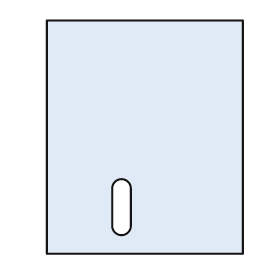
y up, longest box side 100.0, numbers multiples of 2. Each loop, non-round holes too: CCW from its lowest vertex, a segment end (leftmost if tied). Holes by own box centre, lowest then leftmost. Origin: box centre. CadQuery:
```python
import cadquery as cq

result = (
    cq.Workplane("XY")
    .moveTo(-42.0, -50.0)
    .lineTo(42.0, -50.0)
    .lineTo(42.0, 50.0)
    .lineTo(-42.0, 50.0)
    .close()
    .moveTo(-14.0, -38.0)
    .threePointArc((-10.0, -42.0), (-6.0, -38.0))
    .lineTo(-6.0, -22.0)
    .threePointArc((-10.0, -18.0), (-14.0, -22.0))
    .close()
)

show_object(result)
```